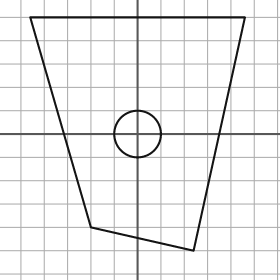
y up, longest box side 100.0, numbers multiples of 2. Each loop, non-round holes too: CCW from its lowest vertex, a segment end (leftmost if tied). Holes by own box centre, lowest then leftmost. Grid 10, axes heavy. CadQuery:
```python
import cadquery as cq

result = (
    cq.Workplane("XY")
    .moveTo(24.0, -50.0)
    .lineTo(46.0, 50.0)
    .lineTo(-46.0, 50.0)
    .lineTo(-20.0, -40.0)
    .close()
    .moveTo(0.0, 0.0)
    .circle(10.0)
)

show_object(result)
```